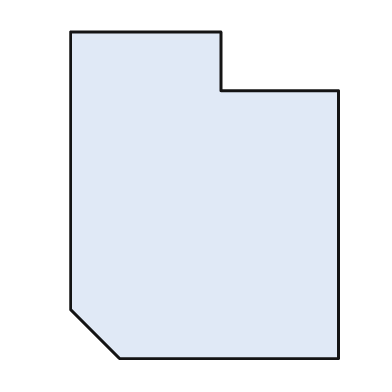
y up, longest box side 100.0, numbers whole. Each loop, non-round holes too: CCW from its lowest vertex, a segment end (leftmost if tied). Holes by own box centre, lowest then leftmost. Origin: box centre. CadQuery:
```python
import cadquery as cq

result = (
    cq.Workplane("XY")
    .moveTo(-26.0, -50.0)
    .lineTo(41.0, -50.0)
    .lineTo(41.0, 32.0)
    .lineTo(5.0, 32.0)
    .lineTo(5.0, 50.0)
    .lineTo(-41.0, 50.0)
    .lineTo(-41.0, -35.0)
    .close()
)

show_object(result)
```